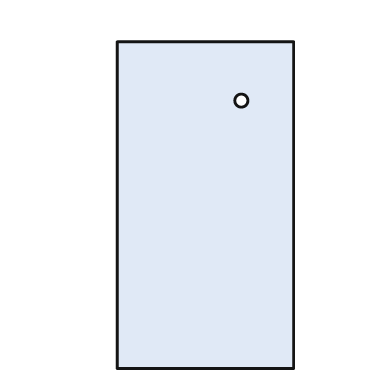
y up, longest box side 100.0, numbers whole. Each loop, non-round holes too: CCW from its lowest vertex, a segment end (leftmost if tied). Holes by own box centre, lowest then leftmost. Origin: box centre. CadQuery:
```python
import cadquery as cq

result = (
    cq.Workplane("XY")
    .moveTo(-27.0, -50.0)
    .lineTo(27.0, -50.0)
    .lineTo(27.0, 50.0)
    .lineTo(-27.0, 50.0)
    .close()
    .moveTo(11.0, 32.0)
    .circle(2.0)
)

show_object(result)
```